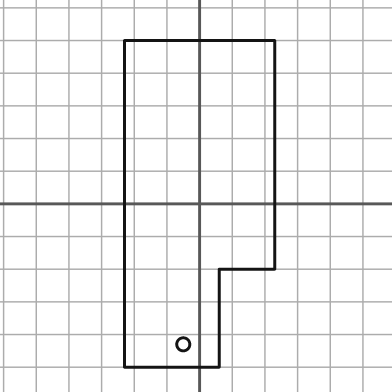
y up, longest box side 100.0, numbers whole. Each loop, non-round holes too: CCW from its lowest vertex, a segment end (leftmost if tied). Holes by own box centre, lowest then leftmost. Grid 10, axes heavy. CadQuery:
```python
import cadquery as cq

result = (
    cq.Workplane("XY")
    .moveTo(-23.0, -50.0)
    .lineTo(6.0, -50.0)
    .lineTo(6.0, -20.0)
    .lineTo(23.0, -20.0)
    .lineTo(23.0, 50.0)
    .lineTo(-23.0, 50.0)
    .close()
    .moveTo(-5.0, -43.0)
    .circle(2.0)
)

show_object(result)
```